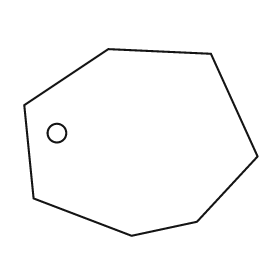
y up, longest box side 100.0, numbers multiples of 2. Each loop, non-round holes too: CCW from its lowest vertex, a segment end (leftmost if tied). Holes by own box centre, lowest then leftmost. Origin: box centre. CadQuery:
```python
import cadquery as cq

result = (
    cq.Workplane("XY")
    .moveTo(-4.0, -40.0)
    .lineTo(24.0, -34.0)
    .lineTo(50.0, -6.0)
    .lineTo(30.0, 38.0)
    .lineTo(-14.0, 40.0)
    .lineTo(-50.0, 16.0)
    .lineTo(-46.0, -24.0)
    .close()
    .moveTo(-36.0, 4.0)
    .circle(4.0)
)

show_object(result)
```